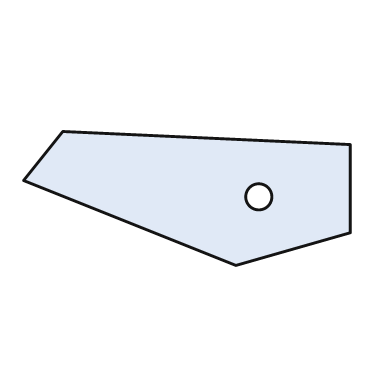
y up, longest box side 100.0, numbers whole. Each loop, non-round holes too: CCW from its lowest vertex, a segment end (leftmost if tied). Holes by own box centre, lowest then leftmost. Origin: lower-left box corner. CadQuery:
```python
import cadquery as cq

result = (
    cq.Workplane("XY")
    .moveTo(65.0, 0.0)
    .lineTo(100.0, 10.0)
    .lineTo(100.0, 37.0)
    .lineTo(12.0, 41.0)
    .lineTo(0.0, 26.0)
    .close()
    .moveTo(72.0, 21.0)
    .circle(4.0)
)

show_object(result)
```